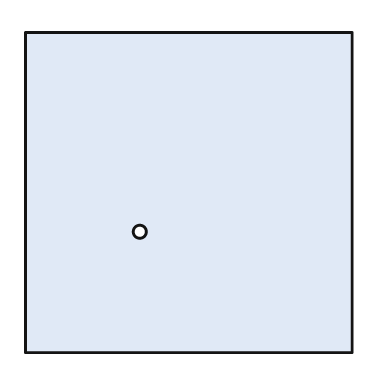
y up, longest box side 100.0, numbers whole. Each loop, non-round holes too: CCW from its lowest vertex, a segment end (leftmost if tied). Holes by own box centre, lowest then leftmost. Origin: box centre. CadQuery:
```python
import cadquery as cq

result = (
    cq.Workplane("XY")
    .moveTo(-50.0, -49.0)
    .lineTo(50.0, -49.0)
    .lineTo(50.0, 49.0)
    .lineTo(-50.0, 49.0)
    .close()
    .moveTo(-15.0, -12.0)
    .circle(2.0)
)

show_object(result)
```